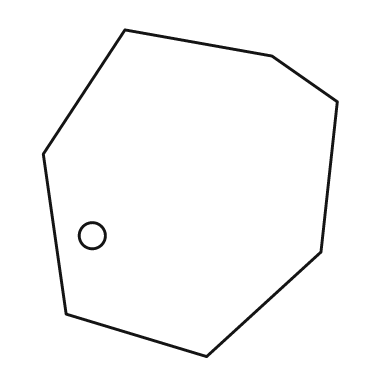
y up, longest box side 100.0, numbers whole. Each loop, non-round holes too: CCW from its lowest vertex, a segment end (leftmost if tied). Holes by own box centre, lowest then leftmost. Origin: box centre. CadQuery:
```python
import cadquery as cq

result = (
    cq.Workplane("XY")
    .moveTo(5.0, -50.0)
    .lineTo(40.0, -18.0)
    .lineTo(45.0, 28.0)
    .lineTo(25.0, 42.0)
    .lineTo(-20.0, 50.0)
    .lineTo(-45.0, 12.0)
    .lineTo(-38.0, -37.0)
    .close()
    .moveTo(-30.0, -13.0)
    .circle(4.0)
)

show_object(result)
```